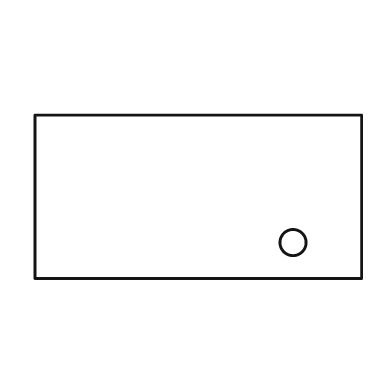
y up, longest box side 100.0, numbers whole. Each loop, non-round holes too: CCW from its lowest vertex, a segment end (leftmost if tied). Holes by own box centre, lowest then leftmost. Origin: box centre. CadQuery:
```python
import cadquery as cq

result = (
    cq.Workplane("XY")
    .moveTo(-50.0, -25.0)
    .lineTo(50.0, -25.0)
    .lineTo(50.0, 25.0)
    .lineTo(-50.0, 25.0)
    .close()
    .moveTo(29.0, -14.0)
    .circle(4.0)
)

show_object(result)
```